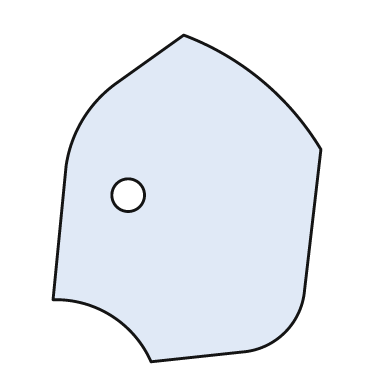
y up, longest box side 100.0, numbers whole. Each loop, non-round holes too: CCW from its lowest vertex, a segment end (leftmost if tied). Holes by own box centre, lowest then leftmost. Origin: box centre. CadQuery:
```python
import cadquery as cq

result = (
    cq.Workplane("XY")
    .moveTo(-11.0, -50.0)
    .lineTo(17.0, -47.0)
    .threePointArc((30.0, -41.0), (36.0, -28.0))
    .lineTo(41.0, 15.0)
    .threePointArc((23.0, 36.0), (-1.0, 50.0))
    .lineTo(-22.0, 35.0)
    .threePointArc((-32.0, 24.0), (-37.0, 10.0))
    .lineTo(-41.0, -31.0)
    .threePointArc((-23.0, -36.0), (-11.0, -50.0))
    .close()
    .moveTo(-18.0, 1.0)
    .circle(5.0)
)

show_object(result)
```